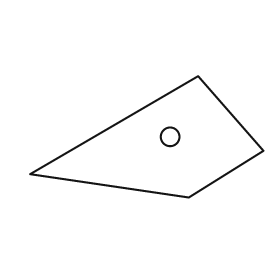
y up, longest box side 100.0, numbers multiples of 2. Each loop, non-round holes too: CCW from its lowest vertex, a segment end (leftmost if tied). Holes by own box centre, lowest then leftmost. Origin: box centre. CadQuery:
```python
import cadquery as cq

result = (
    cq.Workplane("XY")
    .moveTo(18.0, -26.0)
    .lineTo(50.0, -6.0)
    .lineTo(22.0, 26.0)
    .lineTo(-50.0, -16.0)
    .close()
    .moveTo(10.0, 0.0)
    .circle(4.0)
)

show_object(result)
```